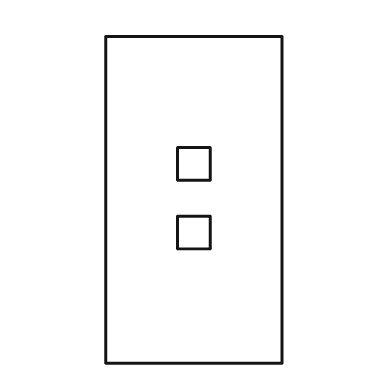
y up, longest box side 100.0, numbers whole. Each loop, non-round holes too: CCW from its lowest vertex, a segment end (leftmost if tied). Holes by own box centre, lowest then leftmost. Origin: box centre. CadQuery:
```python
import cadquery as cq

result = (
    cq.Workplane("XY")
    .moveTo(-27.0, -50.0)
    .lineTo(27.0, -50.0)
    .lineTo(27.0, 50.0)
    .lineTo(-27.0, 50.0)
    .close()
    .moveTo(-5.0, -15.0)
    .lineTo(5.0, -15.0)
    .lineTo(5.0, -5.0)
    .lineTo(-5.0, -5.0)
    .close()
    .moveTo(-5.0, 6.0)
    .lineTo(5.0, 6.0)
    .lineTo(5.0, 16.0)
    .lineTo(-5.0, 16.0)
    .close()
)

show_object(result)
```